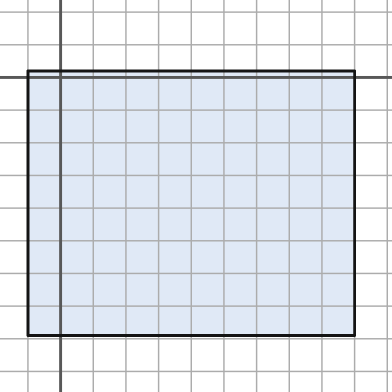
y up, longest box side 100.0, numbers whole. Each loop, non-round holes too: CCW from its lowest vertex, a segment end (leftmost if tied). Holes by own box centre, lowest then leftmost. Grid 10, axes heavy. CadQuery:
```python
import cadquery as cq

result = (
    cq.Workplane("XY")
    .moveTo(-10.0, -79.0)
    .lineTo(90.0, -79.0)
    .lineTo(90.0, 2.0)
    .lineTo(-10.0, 2.0)
    .close()
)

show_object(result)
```